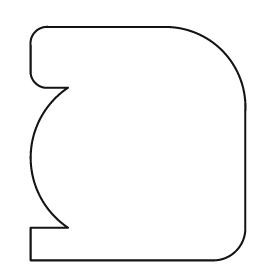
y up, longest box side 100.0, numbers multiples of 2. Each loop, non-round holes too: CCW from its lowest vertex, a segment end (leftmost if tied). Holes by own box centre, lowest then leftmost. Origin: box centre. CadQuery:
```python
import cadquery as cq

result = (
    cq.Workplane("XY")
    .moveTo(-46.0, -50.0)
    .lineTo(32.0, -50.0)
    .threePointArc((42.0, -46.0), (46.0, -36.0))
    .lineTo(46.0, 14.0)
    .threePointArc((36.0, 40.0), (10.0, 50.0))
    .lineTo(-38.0, 50.0)
    .threePointArc((-44.0, 48.0), (-46.0, 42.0))
    .lineTo(-46.0, 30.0)
    .threePointArc((-44.0, 26.0), (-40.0, 24.0))
    .lineTo(-30.0, 24.0)
    .threePointArc((-46.0, -6.0), (-30.0, -36.0))
    .lineTo(-46.0, -36.0)
    .close()
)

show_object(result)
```